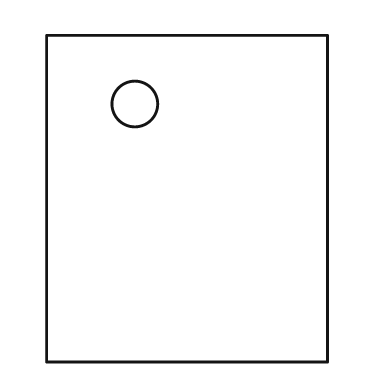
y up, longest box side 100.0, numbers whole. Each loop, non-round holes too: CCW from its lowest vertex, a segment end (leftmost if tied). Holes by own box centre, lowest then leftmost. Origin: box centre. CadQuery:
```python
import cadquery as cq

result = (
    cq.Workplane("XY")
    .moveTo(-43.0, -50.0)
    .lineTo(43.0, -50.0)
    .lineTo(43.0, 50.0)
    .lineTo(-43.0, 50.0)
    .close()
    .moveTo(-16.0, 29.0)
    .circle(7.0)
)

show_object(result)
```